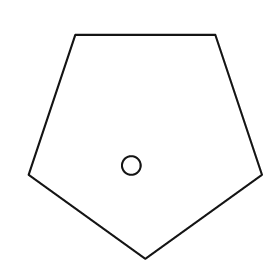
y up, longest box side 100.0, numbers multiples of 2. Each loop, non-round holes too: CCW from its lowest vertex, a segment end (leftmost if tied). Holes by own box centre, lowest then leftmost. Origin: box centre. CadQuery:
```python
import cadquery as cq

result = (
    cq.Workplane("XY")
    .moveTo(0.0, -48.0)
    .lineTo(50.0, -12.0)
    .lineTo(30.0, 48.0)
    .lineTo(-30.0, 48.0)
    .lineTo(-50.0, -12.0)
    .close()
    .moveTo(-6.0, -8.0)
    .circle(4.0)
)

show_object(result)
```